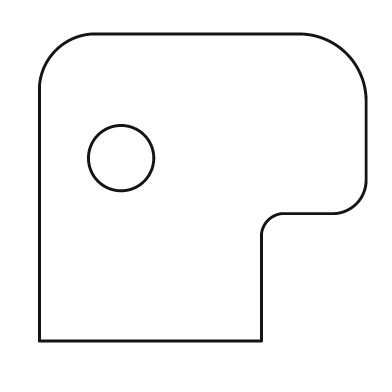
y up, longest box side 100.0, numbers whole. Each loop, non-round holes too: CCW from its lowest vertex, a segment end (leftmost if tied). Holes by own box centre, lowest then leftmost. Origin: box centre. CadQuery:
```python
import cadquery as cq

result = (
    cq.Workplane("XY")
    .moveTo(-50.0, -47.0)
    .lineTo(18.0, -47.0)
    .lineTo(18.0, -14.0)
    .threePointArc((20.0, -10.0), (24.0, -8.0))
    .lineTo(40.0, -8.0)
    .threePointArc((47.0, -5.0), (50.0, 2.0))
    .lineTo(50.0, 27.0)
    .threePointArc((44.0, 41.0), (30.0, 47.0))
    .lineTo(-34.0, 47.0)
    .threePointArc((-45.0, 42.0), (-50.0, 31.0))
    .close()
    .moveTo(-25.0, 9.0)
    .circle(10.0)
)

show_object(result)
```